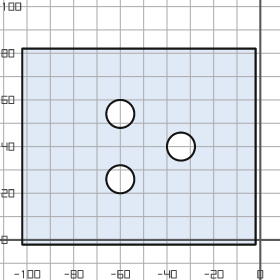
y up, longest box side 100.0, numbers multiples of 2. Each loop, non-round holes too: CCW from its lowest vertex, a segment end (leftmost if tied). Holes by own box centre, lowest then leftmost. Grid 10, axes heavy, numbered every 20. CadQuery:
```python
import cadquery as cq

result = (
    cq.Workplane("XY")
    .moveTo(-102.0, -2.0)
    .lineTo(-2.0, -2.0)
    .lineTo(-2.0, 82.0)
    .lineTo(-102.0, 82.0)
    .close()
    .moveTo(-60.0, 26.0)
    .circle(6.0)
    .moveTo(-34.0, 40.0)
    .circle(6.0)
    .moveTo(-60.0, 54.0)
    .circle(6.0)
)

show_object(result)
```